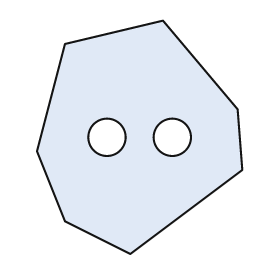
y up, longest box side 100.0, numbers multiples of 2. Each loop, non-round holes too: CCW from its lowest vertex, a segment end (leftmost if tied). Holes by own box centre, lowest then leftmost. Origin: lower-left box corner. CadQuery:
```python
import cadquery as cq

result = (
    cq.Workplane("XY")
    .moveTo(40.0, 0.0)
    .lineTo(88.0, 36.0)
    .lineTo(86.0, 62.0)
    .lineTo(54.0, 100.0)
    .lineTo(12.0, 90.0)
    .lineTo(0.0, 44.0)
    .lineTo(12.0, 14.0)
    .close()
    .moveTo(30.0, 50.0)
    .circle(8.0)
    .moveTo(58.0, 50.0)
    .circle(8.0)
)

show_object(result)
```